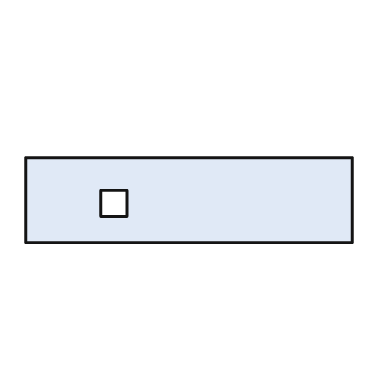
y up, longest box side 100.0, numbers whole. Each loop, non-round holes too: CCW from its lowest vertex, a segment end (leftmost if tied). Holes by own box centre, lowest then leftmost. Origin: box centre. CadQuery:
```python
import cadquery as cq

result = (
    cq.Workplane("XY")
    .moveTo(-50.0, -13.0)
    .lineTo(50.0, -13.0)
    .lineTo(50.0, 13.0)
    .lineTo(-50.0, 13.0)
    .close()
    .moveTo(-27.0, -5.0)
    .lineTo(-19.0, -5.0)
    .lineTo(-19.0, 3.0)
    .lineTo(-27.0, 3.0)
    .close()
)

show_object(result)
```